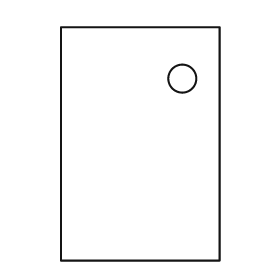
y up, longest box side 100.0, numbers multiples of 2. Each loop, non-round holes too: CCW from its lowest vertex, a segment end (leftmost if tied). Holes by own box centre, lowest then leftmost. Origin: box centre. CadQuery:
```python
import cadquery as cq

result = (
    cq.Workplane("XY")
    .moveTo(-34.0, -50.0)
    .lineTo(34.0, -50.0)
    .lineTo(34.0, 50.0)
    .lineTo(-34.0, 50.0)
    .close()
    .moveTo(18.0, 28.0)
    .circle(6.0)
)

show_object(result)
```